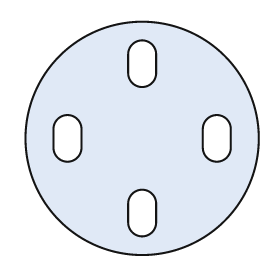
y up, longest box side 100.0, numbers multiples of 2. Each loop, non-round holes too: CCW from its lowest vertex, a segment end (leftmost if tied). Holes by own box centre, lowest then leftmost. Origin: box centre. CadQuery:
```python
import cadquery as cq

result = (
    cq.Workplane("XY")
    .moveTo(0.0, 0.0)
    .circle(50.0)
    .moveTo(-6.0, -36.0)
    .threePointArc((0.0, -42.0), (6.0, -36.0))
    .lineTo(6.0, -28.0)
    .threePointArc((0.0, -22.0), (-6.0, -28.0))
    .close()
    .moveTo(-38.0, -4.0)
    .threePointArc((-32.0, -10.0), (-26.0, -4.0))
    .lineTo(-26.0, 4.0)
    .threePointArc((-32.0, 10.0), (-38.0, 4.0))
    .close()
    .moveTo(26.0, -4.0)
    .threePointArc((32.0, -10.0), (38.0, -4.0))
    .lineTo(38.0, 4.0)
    .threePointArc((32.0, 10.0), (26.0, 4.0))
    .close()
    .moveTo(-6.0, 28.0)
    .threePointArc((0.0, 22.0), (6.0, 28.0))
    .lineTo(6.0, 36.0)
    .threePointArc((0.0, 42.0), (-6.0, 36.0))
    .close()
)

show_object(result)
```